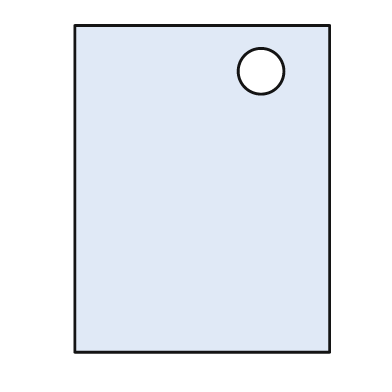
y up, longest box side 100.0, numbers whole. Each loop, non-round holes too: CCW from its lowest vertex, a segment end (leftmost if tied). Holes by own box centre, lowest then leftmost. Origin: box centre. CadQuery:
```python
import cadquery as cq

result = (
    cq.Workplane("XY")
    .moveTo(-39.0, -50.0)
    .lineTo(39.0, -50.0)
    .lineTo(39.0, 50.0)
    .lineTo(-39.0, 50.0)
    .close()
    .moveTo(18.0, 36.0)
    .circle(7.0)
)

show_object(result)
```